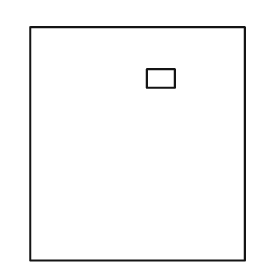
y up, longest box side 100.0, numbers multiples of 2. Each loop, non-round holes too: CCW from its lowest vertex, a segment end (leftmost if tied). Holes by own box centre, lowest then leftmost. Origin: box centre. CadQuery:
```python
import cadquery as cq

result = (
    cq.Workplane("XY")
    .moveTo(-46.0, -50.0)
    .lineTo(46.0, -50.0)
    .lineTo(46.0, 50.0)
    .lineTo(-46.0, 50.0)
    .close()
    .moveTo(4.0, 24.0)
    .lineTo(16.0, 24.0)
    .lineTo(16.0, 32.0)
    .lineTo(4.0, 32.0)
    .close()
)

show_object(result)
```